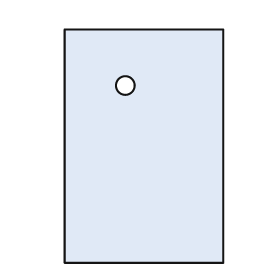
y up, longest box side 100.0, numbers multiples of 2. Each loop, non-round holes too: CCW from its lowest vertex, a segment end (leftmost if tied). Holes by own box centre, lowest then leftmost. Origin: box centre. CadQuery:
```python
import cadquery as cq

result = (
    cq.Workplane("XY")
    .moveTo(-34.0, -50.0)
    .lineTo(34.0, -50.0)
    .lineTo(34.0, 50.0)
    .lineTo(-34.0, 50.0)
    .close()
    .moveTo(-8.0, 26.0)
    .circle(4.0)
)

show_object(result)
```